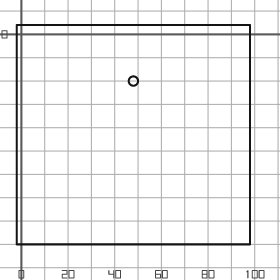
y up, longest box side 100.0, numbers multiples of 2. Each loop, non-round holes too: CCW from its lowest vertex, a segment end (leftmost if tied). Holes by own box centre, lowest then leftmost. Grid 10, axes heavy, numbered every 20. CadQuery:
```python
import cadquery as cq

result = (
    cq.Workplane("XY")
    .moveTo(-2.0, -90.0)
    .lineTo(98.0, -90.0)
    .lineTo(98.0, 4.0)
    .lineTo(-2.0, 4.0)
    .close()
    .moveTo(48.0, -20.0)
    .circle(2.0)
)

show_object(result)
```